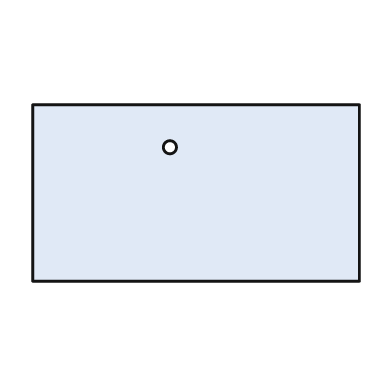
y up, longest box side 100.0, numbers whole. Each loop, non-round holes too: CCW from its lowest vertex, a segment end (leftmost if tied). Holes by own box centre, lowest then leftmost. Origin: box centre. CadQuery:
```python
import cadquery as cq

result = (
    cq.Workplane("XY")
    .moveTo(-50.0, -27.0)
    .lineTo(50.0, -27.0)
    .lineTo(50.0, 27.0)
    .lineTo(-50.0, 27.0)
    .close()
    .moveTo(-8.0, 14.0)
    .circle(2.0)
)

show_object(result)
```